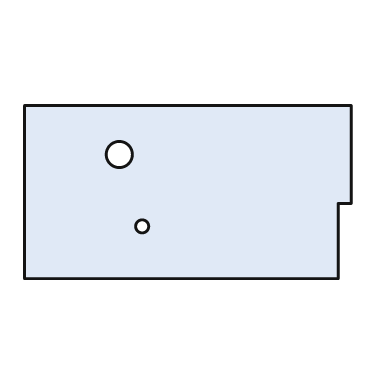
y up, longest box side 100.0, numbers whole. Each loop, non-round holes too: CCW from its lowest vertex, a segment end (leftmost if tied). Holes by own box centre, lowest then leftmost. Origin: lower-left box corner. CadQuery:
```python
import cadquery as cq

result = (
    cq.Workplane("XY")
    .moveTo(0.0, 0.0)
    .lineTo(96.0, 0.0)
    .lineTo(96.0, 23.0)
    .lineTo(100.0, 23.0)
    .lineTo(100.0, 53.0)
    .lineTo(0.0, 53.0)
    .close()
    .moveTo(36.0, 16.0)
    .circle(2.0)
    .moveTo(29.0, 38.0)
    .circle(4.0)
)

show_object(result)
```